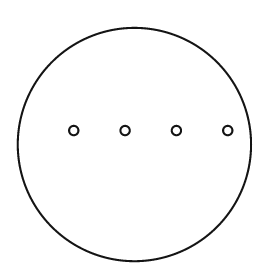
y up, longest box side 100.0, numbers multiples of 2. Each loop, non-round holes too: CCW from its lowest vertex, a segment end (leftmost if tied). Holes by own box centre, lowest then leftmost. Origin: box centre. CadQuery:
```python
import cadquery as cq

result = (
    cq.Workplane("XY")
    .moveTo(0.0, 0.0)
    .circle(50.0)
    .moveTo(-26.0, 6.0)
    .circle(2.0)
    .moveTo(-4.0, 6.0)
    .circle(2.0)
    .moveTo(18.0, 6.0)
    .circle(2.0)
    .moveTo(40.0, 6.0)
    .circle(2.0)
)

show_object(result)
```